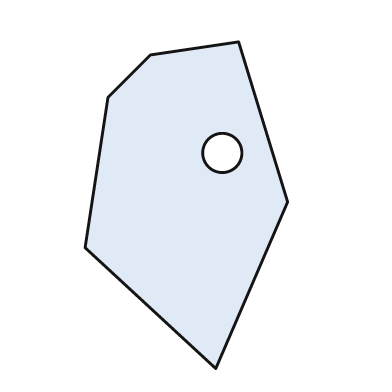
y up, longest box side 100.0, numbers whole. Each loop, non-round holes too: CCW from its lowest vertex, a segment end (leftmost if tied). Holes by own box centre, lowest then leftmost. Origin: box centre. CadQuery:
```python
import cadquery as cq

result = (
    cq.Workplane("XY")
    .moveTo(9.0, -50.0)
    .lineTo(31.0, 1.0)
    .lineTo(16.0, 50.0)
    .lineTo(-11.0, 46.0)
    .lineTo(-24.0, 33.0)
    .lineTo(-31.0, -13.0)
    .close()
    .moveTo(11.0, 16.0)
    .circle(6.0)
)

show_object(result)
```